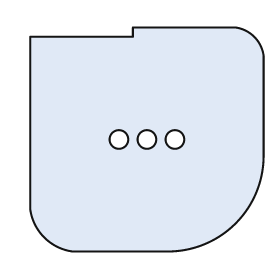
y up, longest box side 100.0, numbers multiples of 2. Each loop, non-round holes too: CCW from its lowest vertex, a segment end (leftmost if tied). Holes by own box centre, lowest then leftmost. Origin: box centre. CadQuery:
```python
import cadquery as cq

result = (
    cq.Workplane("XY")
    .moveTo(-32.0, -48.0)
    .lineTo(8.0, -48.0)
    .threePointArc((38.0, -36.0), (50.0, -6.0))
    .lineTo(50.0, 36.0)
    .threePointArc((46.0, 44.0), (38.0, 48.0))
    .lineTo(-6.0, 48.0)
    .lineTo(-6.0, 44.0)
    .lineTo(-50.0, 44.0)
    .lineTo(-50.0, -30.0)
    .threePointArc((-44.0, -42.0), (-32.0, -48.0))
    .close()
    .moveTo(-12.0, 0.0)
    .circle(4.0)
    .moveTo(0.0, 0.0)
    .circle(4.0)
    .moveTo(12.0, 0.0)
    .circle(4.0)
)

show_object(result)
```